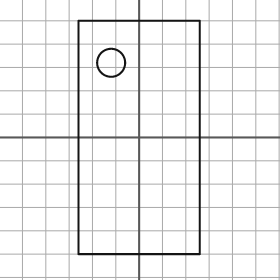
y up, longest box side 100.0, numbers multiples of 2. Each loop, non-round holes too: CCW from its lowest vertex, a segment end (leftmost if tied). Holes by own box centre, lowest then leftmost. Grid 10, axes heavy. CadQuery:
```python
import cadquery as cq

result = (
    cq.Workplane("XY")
    .moveTo(-26.0, -50.0)
    .lineTo(26.0, -50.0)
    .lineTo(26.0, 50.0)
    .lineTo(-26.0, 50.0)
    .close()
    .moveTo(-12.0, 32.0)
    .circle(6.0)
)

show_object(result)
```